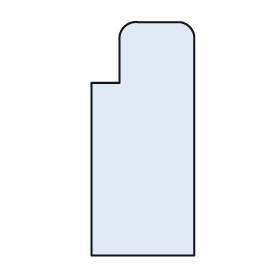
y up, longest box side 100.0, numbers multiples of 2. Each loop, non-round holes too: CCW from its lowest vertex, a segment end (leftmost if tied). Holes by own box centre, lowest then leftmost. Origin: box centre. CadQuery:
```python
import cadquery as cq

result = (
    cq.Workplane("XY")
    .moveTo(-22.0, -50.0)
    .lineTo(22.0, -50.0)
    .lineTo(22.0, 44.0)
    .threePointArc((20.0, 48.0), (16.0, 50.0))
    .lineTo(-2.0, 50.0)
    .threePointArc((-8.0, 48.0), (-10.0, 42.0))
    .lineTo(-10.0, 24.0)
    .lineTo(-22.0, 24.0)
    .close()
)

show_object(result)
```